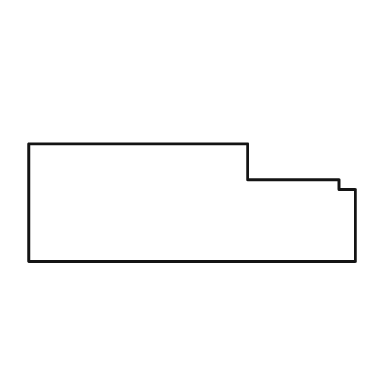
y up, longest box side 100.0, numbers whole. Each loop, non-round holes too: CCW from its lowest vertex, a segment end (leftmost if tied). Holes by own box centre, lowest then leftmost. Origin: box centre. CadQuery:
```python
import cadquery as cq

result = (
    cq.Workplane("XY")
    .moveTo(-50.0, -18.0)
    .lineTo(50.0, -18.0)
    .lineTo(50.0, 4.0)
    .lineTo(45.0, 4.0)
    .lineTo(45.0, 7.0)
    .lineTo(17.0, 7.0)
    .lineTo(17.0, 18.0)
    .lineTo(-50.0, 18.0)
    .close()
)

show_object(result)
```